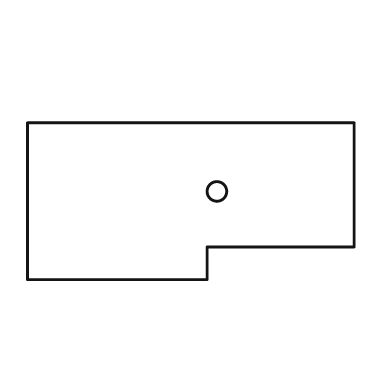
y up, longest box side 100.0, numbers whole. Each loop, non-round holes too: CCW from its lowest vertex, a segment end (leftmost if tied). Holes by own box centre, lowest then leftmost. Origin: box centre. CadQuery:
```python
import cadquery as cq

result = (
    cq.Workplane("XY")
    .moveTo(-50.0, -24.0)
    .lineTo(5.0, -24.0)
    .lineTo(5.0, -14.0)
    .lineTo(50.0, -14.0)
    .lineTo(50.0, 24.0)
    .lineTo(-50.0, 24.0)
    .close()
    .moveTo(8.0, 3.0)
    .circle(3.0)
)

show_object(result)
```